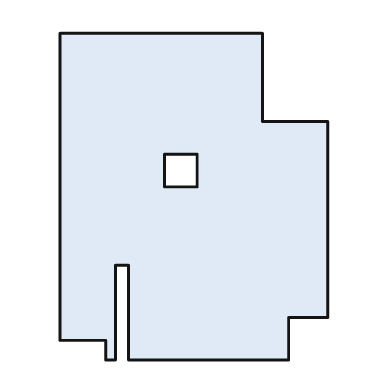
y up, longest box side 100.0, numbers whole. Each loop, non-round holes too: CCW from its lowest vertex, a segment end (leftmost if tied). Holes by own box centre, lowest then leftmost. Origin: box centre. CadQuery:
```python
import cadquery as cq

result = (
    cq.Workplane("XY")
    .moveTo(-27.0, -50.0)
    .lineTo(-24.0, -50.0)
    .lineTo(-24.0, -21.0)
    .lineTo(-20.0, -21.0)
    .lineTo(-20.0, -50.0)
    .lineTo(29.0, -50.0)
    .lineTo(29.0, -37.0)
    .lineTo(41.0, -37.0)
    .lineTo(41.0, 23.0)
    .lineTo(21.0, 23.0)
    .lineTo(21.0, 50.0)
    .lineTo(-41.0, 50.0)
    .lineTo(-41.0, -44.0)
    .lineTo(-27.0, -44.0)
    .close()
    .moveTo(-9.0, 3.0)
    .lineTo(1.0, 3.0)
    .lineTo(1.0, 13.0)
    .lineTo(-9.0, 13.0)
    .close()
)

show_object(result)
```